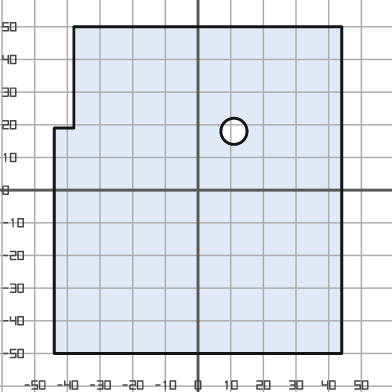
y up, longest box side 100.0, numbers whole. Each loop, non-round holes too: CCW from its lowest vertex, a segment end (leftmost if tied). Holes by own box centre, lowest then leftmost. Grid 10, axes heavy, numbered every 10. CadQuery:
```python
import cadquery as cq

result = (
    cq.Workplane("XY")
    .moveTo(-44.0, -50.0)
    .lineTo(44.0, -50.0)
    .lineTo(44.0, 50.0)
    .lineTo(-38.0, 50.0)
    .lineTo(-38.0, 19.0)
    .lineTo(-44.0, 19.0)
    .close()
    .moveTo(11.0, 18.0)
    .circle(4.0)
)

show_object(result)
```